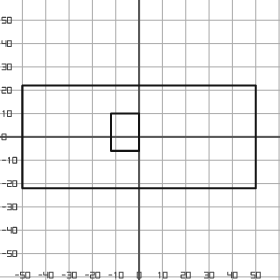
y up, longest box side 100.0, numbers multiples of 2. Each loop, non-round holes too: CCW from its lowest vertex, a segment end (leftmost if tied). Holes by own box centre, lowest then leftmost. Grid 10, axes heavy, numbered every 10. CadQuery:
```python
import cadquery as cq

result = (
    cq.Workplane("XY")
    .moveTo(-50.0, -22.0)
    .lineTo(50.0, -22.0)
    .lineTo(50.0, 22.0)
    .lineTo(-50.0, 22.0)
    .close()
    .moveTo(-12.0, -6.0)
    .lineTo(0.0, -6.0)
    .lineTo(0.0, 10.0)
    .lineTo(-12.0, 10.0)
    .close()
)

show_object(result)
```